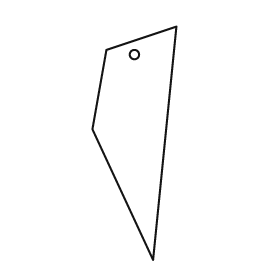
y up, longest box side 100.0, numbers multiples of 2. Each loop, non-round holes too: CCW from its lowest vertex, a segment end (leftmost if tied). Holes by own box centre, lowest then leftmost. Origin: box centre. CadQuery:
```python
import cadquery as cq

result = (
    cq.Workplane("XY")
    .moveTo(8.0, -50.0)
    .lineTo(18.0, 50.0)
    .lineTo(-12.0, 40.0)
    .lineTo(-18.0, 6.0)
    .close()
    .moveTo(0.0, 38.0)
    .circle(2.0)
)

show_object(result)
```